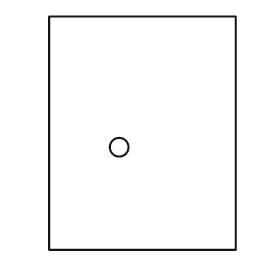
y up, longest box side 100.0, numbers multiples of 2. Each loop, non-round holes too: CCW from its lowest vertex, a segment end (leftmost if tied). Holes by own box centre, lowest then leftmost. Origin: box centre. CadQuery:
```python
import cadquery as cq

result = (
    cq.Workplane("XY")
    .moveTo(-40.0, -50.0)
    .lineTo(40.0, -50.0)
    .lineTo(40.0, 50.0)
    .lineTo(-40.0, 50.0)
    .close()
    .moveTo(-10.0, -6.0)
    .circle(4.0)
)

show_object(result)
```